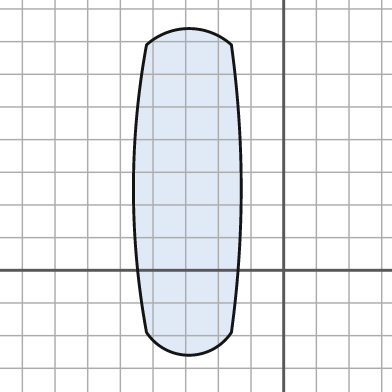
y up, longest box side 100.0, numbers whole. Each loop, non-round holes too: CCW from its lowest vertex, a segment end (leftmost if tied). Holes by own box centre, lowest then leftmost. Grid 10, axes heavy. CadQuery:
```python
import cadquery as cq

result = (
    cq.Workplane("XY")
    .moveTo(-42.0, -19.0)
    .threePointArc((-29.0, -26.0), (-16.0, -19.0))
    .threePointArc((-13.0, 25.0), (-16.0, 69.0))
    .threePointArc((-29.0, 74.0), (-42.0, 69.0))
    .threePointArc((-46.0, 25.0), (-42.0, -19.0))
    .close()
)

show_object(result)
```